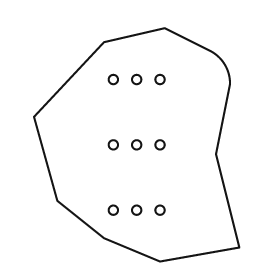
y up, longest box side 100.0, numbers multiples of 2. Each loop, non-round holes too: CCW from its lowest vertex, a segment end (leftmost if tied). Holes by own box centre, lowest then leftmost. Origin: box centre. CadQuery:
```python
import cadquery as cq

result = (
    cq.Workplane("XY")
    .moveTo(10.0, -50.0)
    .lineTo(44.0, -44.0)
    .lineTo(34.0, -4.0)
    .lineTo(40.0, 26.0)
    .threePointArc((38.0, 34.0), (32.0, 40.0))
    .lineTo(12.0, 50.0)
    .lineTo(-14.0, 44.0)
    .lineTo(-44.0, 12.0)
    .lineTo(-34.0, -24.0)
    .lineTo(-14.0, -40.0)
    .close()
    .moveTo(-10.0, -28.0)
    .circle(2.0)
    .moveTo(0.0, -28.0)
    .circle(2.0)
    .moveTo(10.0, -28.0)
    .circle(2.0)
    .moveTo(-10.0, 0.0)
    .circle(2.0)
    .moveTo(0.0, 0.0)
    .circle(2.0)
    .moveTo(10.0, 0.0)
    .circle(2.0)
    .moveTo(-10.0, 28.0)
    .circle(2.0)
    .moveTo(0.0, 28.0)
    .circle(2.0)
    .moveTo(10.0, 28.0)
    .circle(2.0)
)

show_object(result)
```